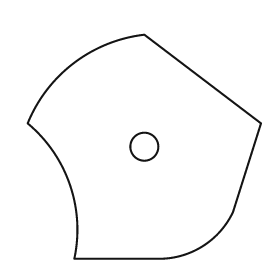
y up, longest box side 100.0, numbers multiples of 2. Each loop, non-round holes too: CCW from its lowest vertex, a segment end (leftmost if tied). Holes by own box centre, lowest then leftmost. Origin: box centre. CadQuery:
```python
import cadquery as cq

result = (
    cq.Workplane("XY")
    .moveTo(-30.0, -48.0)
    .lineTo(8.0, -48.0)
    .threePointArc((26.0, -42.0), (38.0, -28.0))
    .lineTo(50.0, 10.0)
    .lineTo(0.0, 48.0)
    .threePointArc((-30.0, 36.0), (-50.0, 10.0))
    .threePointArc((-32.0, -16.0), (-30.0, -48.0))
    .close()
    .moveTo(0.0, 0.0)
    .circle(6.0)
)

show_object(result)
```